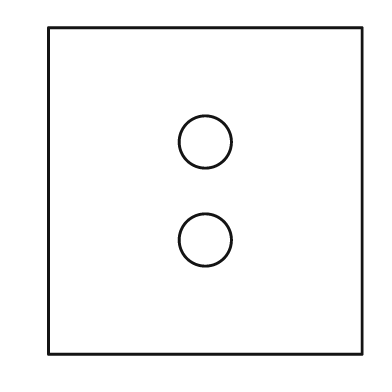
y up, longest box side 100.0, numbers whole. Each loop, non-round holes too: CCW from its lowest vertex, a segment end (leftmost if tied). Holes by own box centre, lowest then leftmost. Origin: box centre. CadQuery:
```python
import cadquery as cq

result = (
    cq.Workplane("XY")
    .moveTo(-48.0, -50.0)
    .lineTo(48.0, -50.0)
    .lineTo(48.0, 50.0)
    .lineTo(-48.0, 50.0)
    .close()
    .moveTo(0.0, -15.0)
    .circle(8.0)
    .moveTo(0.0, 15.0)
    .circle(8.0)
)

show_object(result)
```